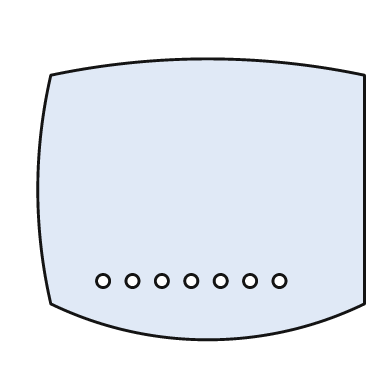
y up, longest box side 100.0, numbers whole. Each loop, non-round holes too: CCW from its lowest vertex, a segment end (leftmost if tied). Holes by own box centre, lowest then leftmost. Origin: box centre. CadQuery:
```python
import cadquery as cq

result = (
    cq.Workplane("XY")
    .moveTo(-46.0, -32.0)
    .threePointArc((2.0, -43.0), (50.0, -32.0))
    .lineTo(50.0, 38.0)
    .threePointArc((2.0, 43.0), (-46.0, 38.0))
    .threePointArc((-50.0, 3.0), (-46.0, -32.0))
    .close()
    .moveTo(-30.0, -25.0)
    .circle(2.0)
    .moveTo(-21.0, -25.0)
    .circle(2.0)
    .moveTo(-12.0, -25.0)
    .circle(2.0)
    .moveTo(-3.0, -25.0)
    .circle(2.0)
    .moveTo(6.0, -25.0)
    .circle(2.0)
    .moveTo(15.0, -25.0)
    .circle(2.0)
    .moveTo(24.0, -25.0)
    .circle(2.0)
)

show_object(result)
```